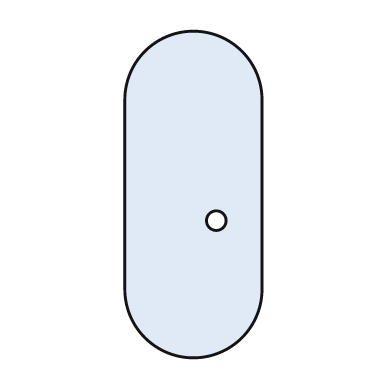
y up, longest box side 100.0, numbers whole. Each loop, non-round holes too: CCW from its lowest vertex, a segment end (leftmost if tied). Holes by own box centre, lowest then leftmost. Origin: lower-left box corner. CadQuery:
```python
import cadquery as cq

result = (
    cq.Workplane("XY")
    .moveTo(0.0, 21.0)
    .threePointArc((21.0, 0.0), (42.0, 21.0))
    .lineTo(42.0, 79.0)
    .threePointArc((21.0, 100.0), (0.0, 79.0))
    .close()
    .moveTo(28.0, 42.0)
    .circle(3.0)
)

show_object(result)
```